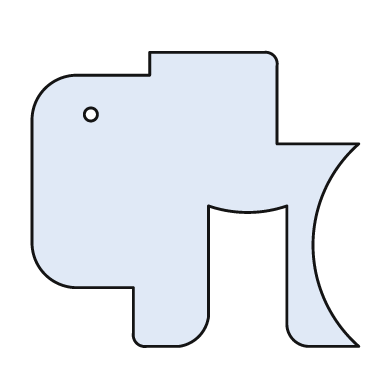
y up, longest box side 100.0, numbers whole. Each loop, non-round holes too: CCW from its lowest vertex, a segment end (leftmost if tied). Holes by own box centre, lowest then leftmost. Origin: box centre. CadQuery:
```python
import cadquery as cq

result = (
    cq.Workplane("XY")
    .moveTo(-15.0, -45.0)
    .lineTo(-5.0, -45.0)
    .threePointArc((1.0, -42.0), (4.0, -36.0))
    .lineTo(4.0, -2.0)
    .threePointArc((16.0, -4.0), (28.0, -2.0))
    .lineTo(28.0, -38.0)
    .threePointArc((30.0, -43.0), (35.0, -45.0))
    .lineTo(50.0, -45.0)
    .threePointArc((36.0, -14.0), (50.0, 17.0))
    .lineTo(25.0, 17.0)
    .lineTo(25.0, 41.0)
    .threePointArc((24.0, 44.0), (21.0, 45.0))
    .lineTo(-14.0, 45.0)
    .lineTo(-14.0, 38.0)
    .lineTo(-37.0, 38.0)
    .threePointArc((-46.0, 34.0), (-50.0, 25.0))
    .lineTo(-50.0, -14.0)
    .threePointArc((-46.0, -23.0), (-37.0, -27.0))
    .lineTo(-19.0, -27.0)
    .lineTo(-19.0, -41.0)
    .threePointArc((-18.0, -44.0), (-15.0, -45.0))
    .close()
    .moveTo(-32.0, 26.0)
    .circle(2.0)
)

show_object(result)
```